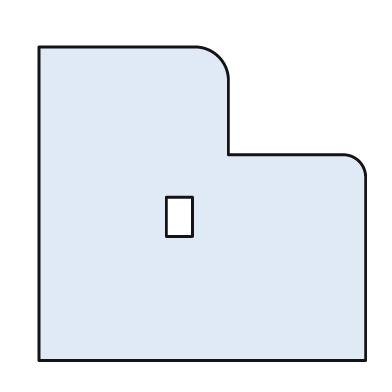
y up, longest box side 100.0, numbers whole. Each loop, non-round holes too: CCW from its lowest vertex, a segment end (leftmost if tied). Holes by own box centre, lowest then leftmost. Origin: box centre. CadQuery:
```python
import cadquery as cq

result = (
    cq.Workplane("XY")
    .moveTo(-50.0, -48.0)
    .lineTo(50.0, -48.0)
    .lineTo(50.0, 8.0)
    .threePointArc((48.0, 13.0), (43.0, 15.0))
    .lineTo(8.0, 15.0)
    .lineTo(8.0, 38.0)
    .threePointArc((5.0, 45.0), (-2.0, 48.0))
    .lineTo(-50.0, 48.0)
    .close()
    .moveTo(-11.0, -10.0)
    .lineTo(-3.0, -10.0)
    .lineTo(-3.0, 2.0)
    .lineTo(-11.0, 2.0)
    .close()
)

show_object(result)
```